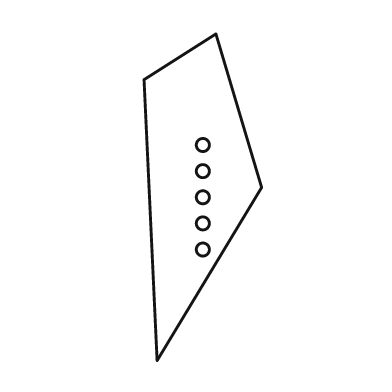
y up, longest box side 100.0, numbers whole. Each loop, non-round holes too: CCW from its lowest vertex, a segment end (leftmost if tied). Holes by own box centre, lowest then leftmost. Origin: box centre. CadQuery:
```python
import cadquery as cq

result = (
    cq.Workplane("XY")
    .moveTo(-14.0, -50.0)
    .lineTo(18.0, 3.0)
    .lineTo(4.0, 50.0)
    .lineTo(-18.0, 36.0)
    .close()
    .moveTo(0.0, -16.0)
    .circle(2.0)
    .moveTo(0.0, -8.0)
    .circle(2.0)
    .moveTo(0.0, 0.0)
    .circle(2.0)
    .moveTo(0.0, 8.0)
    .circle(2.0)
    .moveTo(0.0, 16.0)
    .circle(2.0)
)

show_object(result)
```